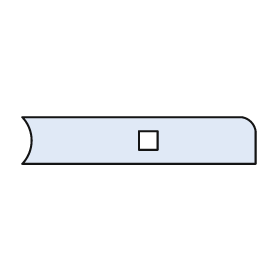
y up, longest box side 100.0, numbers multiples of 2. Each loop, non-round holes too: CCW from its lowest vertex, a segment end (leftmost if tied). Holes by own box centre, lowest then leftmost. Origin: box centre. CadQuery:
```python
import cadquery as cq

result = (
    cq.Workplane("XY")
    .moveTo(-50.0, -10.0)
    .lineTo(50.0, -10.0)
    .lineTo(50.0, 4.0)
    .threePointArc((48.0, 8.0), (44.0, 10.0))
    .lineTo(-50.0, 10.0)
    .threePointArc((-46.0, 0.0), (-50.0, -10.0))
    .close()
    .moveTo(0.0, -4.0)
    .lineTo(8.0, -4.0)
    .lineTo(8.0, 4.0)
    .lineTo(0.0, 4.0)
    .close()
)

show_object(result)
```